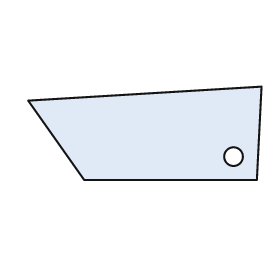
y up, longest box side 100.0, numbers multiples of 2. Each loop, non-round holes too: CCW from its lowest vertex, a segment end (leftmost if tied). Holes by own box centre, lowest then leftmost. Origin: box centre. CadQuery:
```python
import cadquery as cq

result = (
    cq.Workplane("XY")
    .moveTo(-26.0, -20.0)
    .lineTo(48.0, -20.0)
    .lineTo(50.0, 20.0)
    .lineTo(-50.0, 14.0)
    .close()
    .moveTo(38.0, -10.0)
    .circle(4.0)
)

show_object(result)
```